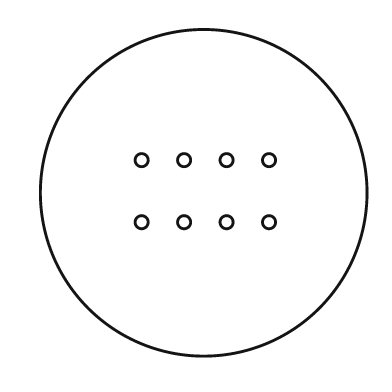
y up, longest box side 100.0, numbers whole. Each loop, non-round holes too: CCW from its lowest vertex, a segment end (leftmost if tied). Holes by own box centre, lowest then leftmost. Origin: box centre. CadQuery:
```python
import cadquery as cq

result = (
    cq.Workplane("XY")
    .moveTo(0.0, 0.0)
    .circle(50.0)
    .moveTo(-19.0, -9.0)
    .circle(2.0)
    .moveTo(-6.0, -9.0)
    .circle(2.0)
    .moveTo(7.0, -9.0)
    .circle(2.0)
    .moveTo(20.0, -9.0)
    .circle(2.0)
    .moveTo(-19.0, 10.0)
    .circle(2.0)
    .moveTo(-6.0, 10.0)
    .circle(2.0)
    .moveTo(7.0, 10.0)
    .circle(2.0)
    .moveTo(20.0, 10.0)
    .circle(2.0)
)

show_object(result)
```